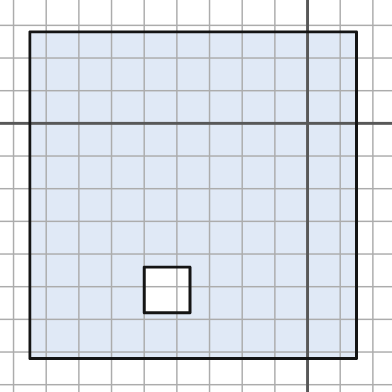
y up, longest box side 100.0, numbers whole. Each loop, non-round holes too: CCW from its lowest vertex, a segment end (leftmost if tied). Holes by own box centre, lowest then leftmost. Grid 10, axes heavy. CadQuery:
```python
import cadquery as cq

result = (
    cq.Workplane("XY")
    .moveTo(-85.0, -72.0)
    .lineTo(15.0, -72.0)
    .lineTo(15.0, 28.0)
    .lineTo(-85.0, 28.0)
    .close()
    .moveTo(-50.0, -58.0)
    .lineTo(-36.0, -58.0)
    .lineTo(-36.0, -44.0)
    .lineTo(-50.0, -44.0)
    .close()
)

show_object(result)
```